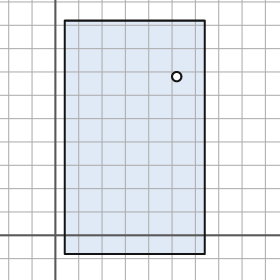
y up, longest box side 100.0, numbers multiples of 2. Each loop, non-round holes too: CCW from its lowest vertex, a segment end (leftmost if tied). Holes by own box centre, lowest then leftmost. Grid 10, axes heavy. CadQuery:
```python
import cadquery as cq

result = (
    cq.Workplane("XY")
    .moveTo(4.0, -8.0)
    .lineTo(64.0, -8.0)
    .lineTo(64.0, 92.0)
    .lineTo(4.0, 92.0)
    .close()
    .moveTo(52.0, 68.0)
    .circle(2.0)
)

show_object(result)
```